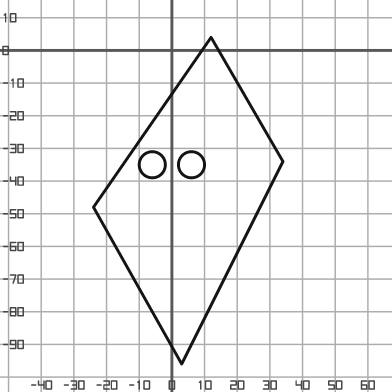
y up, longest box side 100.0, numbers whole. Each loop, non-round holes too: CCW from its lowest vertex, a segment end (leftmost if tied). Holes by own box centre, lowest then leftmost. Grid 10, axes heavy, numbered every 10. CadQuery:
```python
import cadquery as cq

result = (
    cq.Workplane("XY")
    .moveTo(3.0, -96.0)
    .lineTo(34.0, -34.0)
    .lineTo(12.0, 4.0)
    .lineTo(-24.0, -48.0)
    .close()
    .moveTo(-6.0, -35.0)
    .circle(4.0)
    .moveTo(6.0, -35.0)
    .circle(4.0)
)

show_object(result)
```